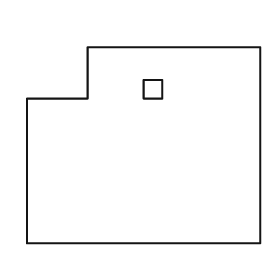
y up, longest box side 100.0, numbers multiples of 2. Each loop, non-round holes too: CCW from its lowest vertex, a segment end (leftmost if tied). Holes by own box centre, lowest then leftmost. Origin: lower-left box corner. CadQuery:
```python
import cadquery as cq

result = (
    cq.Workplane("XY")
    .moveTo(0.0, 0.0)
    .lineTo(100.0, 0.0)
    .lineTo(100.0, 84.0)
    .lineTo(26.0, 84.0)
    .lineTo(26.0, 62.0)
    .lineTo(0.0, 62.0)
    .close()
    .moveTo(50.0, 62.0)
    .lineTo(58.0, 62.0)
    .lineTo(58.0, 70.0)
    .lineTo(50.0, 70.0)
    .close()
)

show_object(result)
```